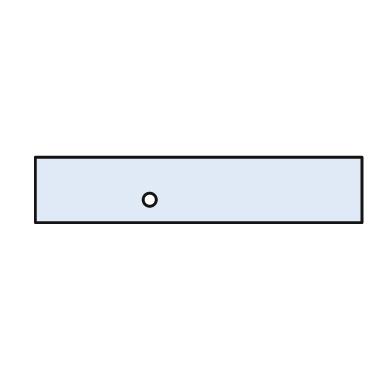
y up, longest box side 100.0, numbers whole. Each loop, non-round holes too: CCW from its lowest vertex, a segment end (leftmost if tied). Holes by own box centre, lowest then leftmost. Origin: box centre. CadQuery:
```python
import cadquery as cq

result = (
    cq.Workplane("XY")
    .moveTo(-50.0, -10.0)
    .lineTo(50.0, -10.0)
    .lineTo(50.0, 10.0)
    .lineTo(-50.0, 10.0)
    .close()
    .moveTo(-15.0, -3.0)
    .circle(2.0)
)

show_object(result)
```